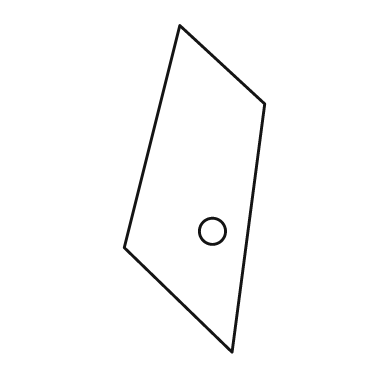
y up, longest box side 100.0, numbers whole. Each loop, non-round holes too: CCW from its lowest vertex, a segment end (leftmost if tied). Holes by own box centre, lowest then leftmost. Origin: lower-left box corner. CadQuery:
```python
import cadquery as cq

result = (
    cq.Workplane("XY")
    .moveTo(33.0, 0.0)
    .lineTo(43.0, 76.0)
    .lineTo(17.0, 100.0)
    .lineTo(0.0, 32.0)
    .close()
    .moveTo(27.0, 37.0)
    .circle(4.0)
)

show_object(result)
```